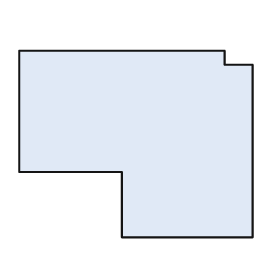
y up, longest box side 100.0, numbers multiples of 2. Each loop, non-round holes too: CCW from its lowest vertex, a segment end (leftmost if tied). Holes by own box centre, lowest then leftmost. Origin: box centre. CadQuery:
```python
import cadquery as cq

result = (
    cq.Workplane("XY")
    .moveTo(-6.0, -40.0)
    .lineTo(50.0, -40.0)
    .lineTo(50.0, 34.0)
    .lineTo(38.0, 34.0)
    .lineTo(38.0, 40.0)
    .lineTo(-50.0, 40.0)
    .lineTo(-50.0, -12.0)
    .lineTo(-6.0, -12.0)
    .close()
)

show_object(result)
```